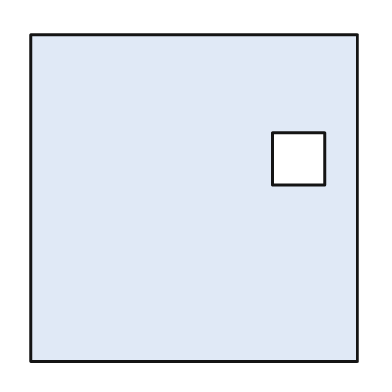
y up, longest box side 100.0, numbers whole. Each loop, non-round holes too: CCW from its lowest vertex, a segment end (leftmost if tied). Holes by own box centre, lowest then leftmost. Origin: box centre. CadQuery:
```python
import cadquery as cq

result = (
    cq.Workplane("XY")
    .moveTo(-50.0, -50.0)
    .lineTo(50.0, -50.0)
    .lineTo(50.0, 50.0)
    .lineTo(-50.0, 50.0)
    .close()
    .moveTo(24.0, 4.0)
    .lineTo(40.0, 4.0)
    .lineTo(40.0, 20.0)
    .lineTo(24.0, 20.0)
    .close()
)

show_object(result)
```